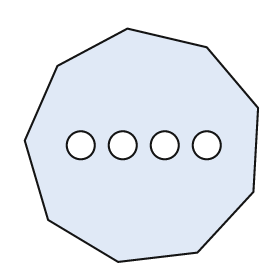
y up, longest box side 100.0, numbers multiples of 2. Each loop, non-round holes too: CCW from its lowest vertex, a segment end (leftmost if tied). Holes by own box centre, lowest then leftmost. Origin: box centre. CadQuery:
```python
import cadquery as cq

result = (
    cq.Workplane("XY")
    .moveTo(-10.0, -50.0)
    .lineTo(24.0, -46.0)
    .lineTo(48.0, -20.0)
    .lineTo(50.0, 16.0)
    .lineTo(28.0, 42.0)
    .lineTo(-6.0, 50.0)
    .lineTo(-36.0, 34.0)
    .lineTo(-50.0, 2.0)
    .lineTo(-40.0, -32.0)
    .close()
    .moveTo(-26.0, 0.0)
    .circle(6.0)
    .moveTo(-8.0, 0.0)
    .circle(6.0)
    .moveTo(10.0, 0.0)
    .circle(6.0)
    .moveTo(28.0, 0.0)
    .circle(6.0)
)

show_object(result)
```